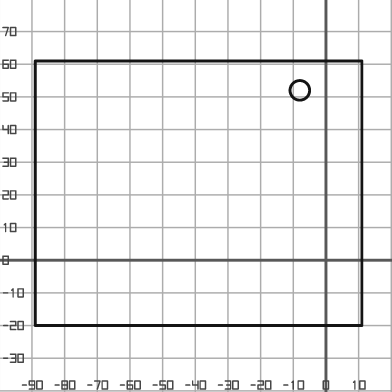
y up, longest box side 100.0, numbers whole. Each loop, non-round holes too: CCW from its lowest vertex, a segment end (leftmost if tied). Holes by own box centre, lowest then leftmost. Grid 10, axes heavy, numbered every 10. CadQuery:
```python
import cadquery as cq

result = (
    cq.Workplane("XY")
    .moveTo(-89.0, -20.0)
    .lineTo(11.0, -20.0)
    .lineTo(11.0, 61.0)
    .lineTo(-89.0, 61.0)
    .close()
    .moveTo(-8.0, 52.0)
    .circle(3.0)
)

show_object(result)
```